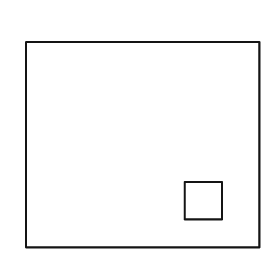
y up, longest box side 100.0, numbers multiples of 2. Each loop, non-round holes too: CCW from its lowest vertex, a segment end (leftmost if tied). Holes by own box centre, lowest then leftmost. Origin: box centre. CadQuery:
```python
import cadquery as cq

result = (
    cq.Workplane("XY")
    .moveTo(-50.0, -44.0)
    .lineTo(50.0, -44.0)
    .lineTo(50.0, 44.0)
    .lineTo(-50.0, 44.0)
    .close()
    .moveTo(18.0, -32.0)
    .lineTo(34.0, -32.0)
    .lineTo(34.0, -16.0)
    .lineTo(18.0, -16.0)
    .close()
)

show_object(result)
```